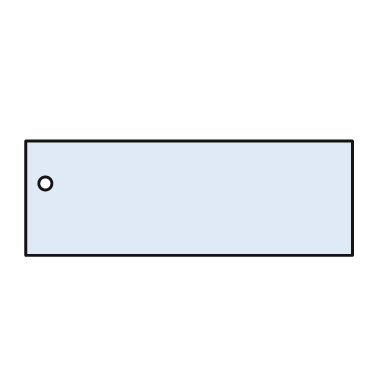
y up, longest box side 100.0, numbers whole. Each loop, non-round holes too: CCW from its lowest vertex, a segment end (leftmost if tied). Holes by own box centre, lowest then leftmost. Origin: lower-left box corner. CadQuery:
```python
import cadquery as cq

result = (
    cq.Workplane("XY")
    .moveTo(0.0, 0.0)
    .lineTo(100.0, 0.0)
    .lineTo(100.0, 35.0)
    .lineTo(0.0, 35.0)
    .close()
    .moveTo(6.0, 22.0)
    .circle(2.0)
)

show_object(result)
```